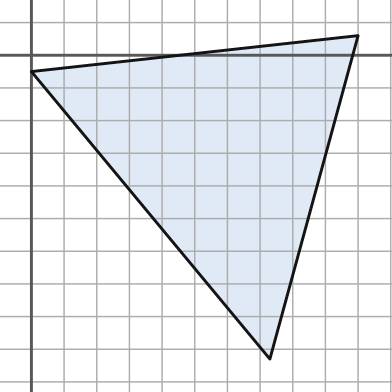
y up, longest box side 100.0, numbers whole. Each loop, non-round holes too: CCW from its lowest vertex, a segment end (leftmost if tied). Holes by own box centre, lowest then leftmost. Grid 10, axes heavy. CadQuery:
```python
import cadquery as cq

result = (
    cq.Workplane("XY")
    .moveTo(73.0, -93.0)
    .lineTo(100.0, 6.0)
    .lineTo(0.0, -5.0)
    .close()
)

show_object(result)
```